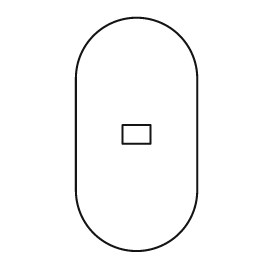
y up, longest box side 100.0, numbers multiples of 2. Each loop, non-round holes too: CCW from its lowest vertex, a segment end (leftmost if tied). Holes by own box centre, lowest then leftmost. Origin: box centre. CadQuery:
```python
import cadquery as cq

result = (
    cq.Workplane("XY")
    .moveTo(-26.0, -24.0)
    .threePointArc((0.0, -50.0), (26.0, -24.0))
    .lineTo(26.0, 24.0)
    .threePointArc((0.0, 50.0), (-26.0, 24.0))
    .close()
    .moveTo(-6.0, -4.0)
    .lineTo(6.0, -4.0)
    .lineTo(6.0, 4.0)
    .lineTo(-6.0, 4.0)
    .close()
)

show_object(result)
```